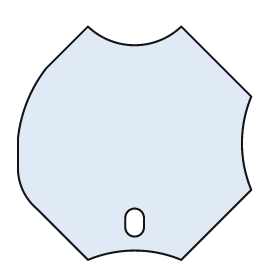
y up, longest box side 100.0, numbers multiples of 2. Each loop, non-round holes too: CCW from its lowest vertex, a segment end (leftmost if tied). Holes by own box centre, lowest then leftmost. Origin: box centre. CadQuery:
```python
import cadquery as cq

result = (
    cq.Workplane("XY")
    .moveTo(-20.0, -50.0)
    .threePointArc((0.0, -46.0), (20.0, -50.0))
    .lineTo(50.0, -20.0)
    .threePointArc((46.0, 0.0), (50.0, 20.0))
    .lineTo(20.0, 50.0)
    .threePointArc((0.0, 42.0), (-20.0, 50.0))
    .lineTo(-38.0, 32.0)
    .threePointArc((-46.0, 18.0), (-50.0, 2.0))
    .lineTo(-50.0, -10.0)
    .threePointArc((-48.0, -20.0), (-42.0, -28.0))
    .close()
    .moveTo(-4.0, -36.0)
    .threePointArc((0.0, -40.0), (4.0, -36.0))
    .lineTo(4.0, -32.0)
    .threePointArc((0.0, -28.0), (-4.0, -32.0))
    .close()
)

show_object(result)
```